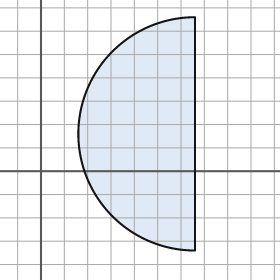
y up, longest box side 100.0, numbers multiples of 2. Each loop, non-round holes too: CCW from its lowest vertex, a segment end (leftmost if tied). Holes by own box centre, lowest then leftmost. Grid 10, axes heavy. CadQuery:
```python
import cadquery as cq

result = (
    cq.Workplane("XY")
    .moveTo(66.0, -34.0)
    .lineTo(66.0, 66.0)
    .threePointArc((16.0, 16.0), (66.0, -34.0))
    .close()
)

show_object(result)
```